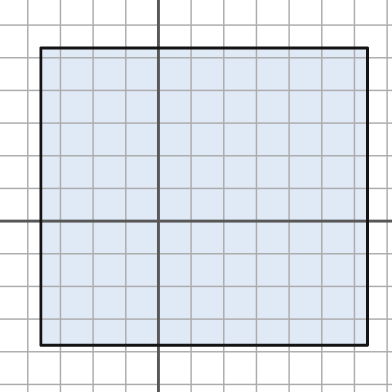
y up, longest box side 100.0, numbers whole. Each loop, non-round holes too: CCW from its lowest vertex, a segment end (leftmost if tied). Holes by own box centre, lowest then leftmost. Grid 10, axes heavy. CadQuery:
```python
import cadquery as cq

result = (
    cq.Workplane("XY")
    .moveTo(-36.0, -38.0)
    .lineTo(64.0, -38.0)
    .lineTo(64.0, 53.0)
    .lineTo(-36.0, 53.0)
    .close()
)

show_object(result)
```